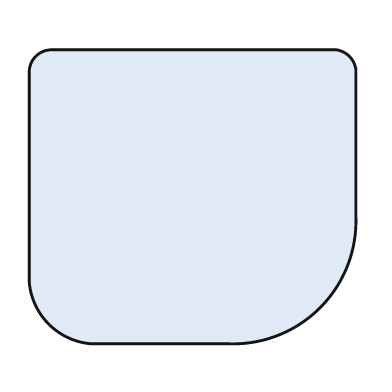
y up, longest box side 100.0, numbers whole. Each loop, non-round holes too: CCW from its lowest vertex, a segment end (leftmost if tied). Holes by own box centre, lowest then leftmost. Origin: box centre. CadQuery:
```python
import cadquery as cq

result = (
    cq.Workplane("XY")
    .moveTo(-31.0, -45.0)
    .lineTo(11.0, -45.0)
    .threePointArc((39.0, -34.0), (50.0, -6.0))
    .lineTo(50.0, 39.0)
    .threePointArc((48.0, 43.0), (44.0, 45.0))
    .lineTo(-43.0, 45.0)
    .threePointArc((-48.0, 43.0), (-50.0, 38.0))
    .lineTo(-50.0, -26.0)
    .threePointArc((-44.0, -39.0), (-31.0, -45.0))
    .close()
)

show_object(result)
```